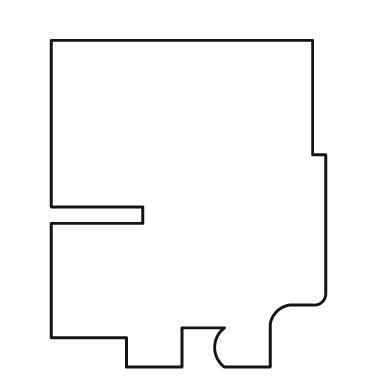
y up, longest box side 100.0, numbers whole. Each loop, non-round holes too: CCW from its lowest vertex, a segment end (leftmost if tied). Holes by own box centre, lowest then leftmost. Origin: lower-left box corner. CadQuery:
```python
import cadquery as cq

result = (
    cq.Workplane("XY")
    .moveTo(23.0, 0.0)
    .lineTo(40.0, 0.0)
    .lineTo(40.0, 12.0)
    .lineTo(53.0, 12.0)
    .threePointArc((50.0, 6.0), (53.0, 0.0))
    .lineTo(67.0, 0.0)
    .lineTo(67.0, 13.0)
    .threePointArc((69.0, 17.0), (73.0, 19.0))
    .lineTo(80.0, 19.0)
    .threePointArc((83.0, 20.0), (84.0, 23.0))
    .lineTo(84.0, 65.0)
    .lineTo(80.0, 65.0)
    .lineTo(80.0, 100.0)
    .lineTo(0.0, 100.0)
    .lineTo(0.0, 49.0)
    .lineTo(28.0, 49.0)
    .lineTo(28.0, 44.0)
    .lineTo(0.0, 44.0)
    .lineTo(0.0, 9.0)
    .lineTo(23.0, 9.0)
    .close()
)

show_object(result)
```